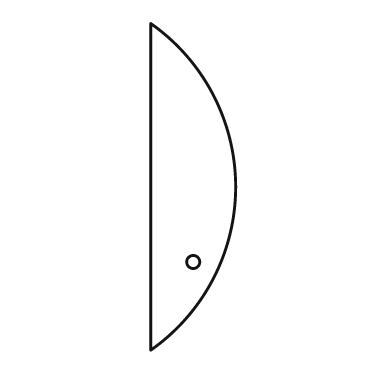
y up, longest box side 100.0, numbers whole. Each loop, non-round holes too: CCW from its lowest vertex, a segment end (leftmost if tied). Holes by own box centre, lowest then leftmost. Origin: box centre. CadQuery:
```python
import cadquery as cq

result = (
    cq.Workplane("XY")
    .moveTo(-13.0, -50.0)
    .threePointArc((13.0, 0.0), (-13.0, 50.0))
    .close()
    .moveTo(0.0, -23.0)
    .circle(2.0)
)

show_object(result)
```